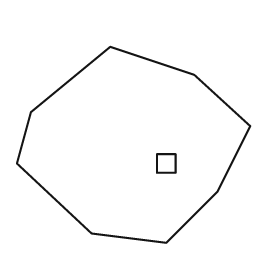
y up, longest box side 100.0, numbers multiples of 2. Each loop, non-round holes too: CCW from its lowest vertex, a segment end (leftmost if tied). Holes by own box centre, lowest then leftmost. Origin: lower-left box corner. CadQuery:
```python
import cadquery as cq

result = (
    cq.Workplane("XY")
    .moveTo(64.0, 0.0)
    .lineTo(86.0, 22.0)
    .lineTo(100.0, 50.0)
    .lineTo(76.0, 72.0)
    .lineTo(40.0, 84.0)
    .lineTo(6.0, 56.0)
    .lineTo(0.0, 34.0)
    .lineTo(32.0, 4.0)
    .close()
    .moveTo(60.0, 30.0)
    .lineTo(68.0, 30.0)
    .lineTo(68.0, 38.0)
    .lineTo(60.0, 38.0)
    .close()
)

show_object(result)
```